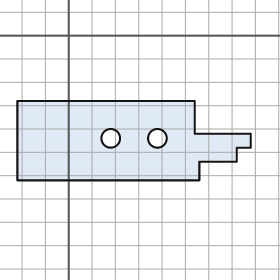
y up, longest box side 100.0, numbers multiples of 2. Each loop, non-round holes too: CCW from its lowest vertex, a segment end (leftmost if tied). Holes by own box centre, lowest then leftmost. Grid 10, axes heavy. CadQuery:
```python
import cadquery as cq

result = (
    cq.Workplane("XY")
    .moveTo(-22.0, -62.0)
    .lineTo(56.0, -62.0)
    .lineTo(56.0, -54.0)
    .lineTo(72.0, -54.0)
    .lineTo(72.0, -48.0)
    .lineTo(78.0, -48.0)
    .lineTo(78.0, -42.0)
    .lineTo(54.0, -42.0)
    .lineTo(54.0, -28.0)
    .lineTo(-22.0, -28.0)
    .close()
    .moveTo(18.0, -44.0)
    .circle(4.0)
    .moveTo(38.0, -44.0)
    .circle(4.0)
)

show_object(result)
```